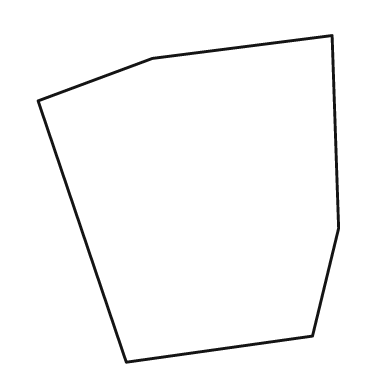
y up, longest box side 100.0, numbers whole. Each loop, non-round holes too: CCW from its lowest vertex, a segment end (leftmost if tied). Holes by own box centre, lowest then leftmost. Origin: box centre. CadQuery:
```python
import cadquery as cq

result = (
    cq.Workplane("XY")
    .moveTo(-19.0, -50.0)
    .lineTo(38.0, -42.0)
    .lineTo(46.0, -9.0)
    .lineTo(44.0, 50.0)
    .lineTo(-11.0, 43.0)
    .lineTo(-46.0, 30.0)
    .close()
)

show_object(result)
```